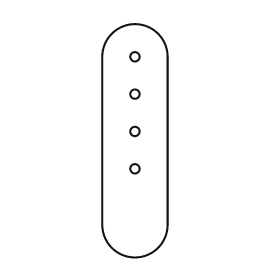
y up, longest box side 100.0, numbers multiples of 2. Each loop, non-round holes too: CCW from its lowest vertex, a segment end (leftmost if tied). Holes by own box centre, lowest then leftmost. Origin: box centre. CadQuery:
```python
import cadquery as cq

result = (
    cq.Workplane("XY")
    .moveTo(-14.0, -36.0)
    .threePointArc((0.0, -50.0), (14.0, -36.0))
    .lineTo(14.0, 36.0)
    .threePointArc((0.0, 50.0), (-14.0, 36.0))
    .close()
    .moveTo(0.0, -12.0)
    .circle(2.0)
    .moveTo(0.0, 4.0)
    .circle(2.0)
    .moveTo(0.0, 20.0)
    .circle(2.0)
    .moveTo(0.0, 36.0)
    .circle(2.0)
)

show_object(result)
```